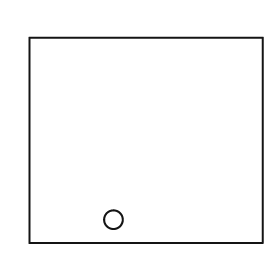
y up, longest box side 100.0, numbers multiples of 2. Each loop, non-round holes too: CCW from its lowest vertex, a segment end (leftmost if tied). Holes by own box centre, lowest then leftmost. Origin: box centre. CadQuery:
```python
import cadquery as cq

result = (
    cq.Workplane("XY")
    .moveTo(-50.0, -44.0)
    .lineTo(50.0, -44.0)
    .lineTo(50.0, 44.0)
    .lineTo(-50.0, 44.0)
    .close()
    .moveTo(-14.0, -34.0)
    .circle(4.0)
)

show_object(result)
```